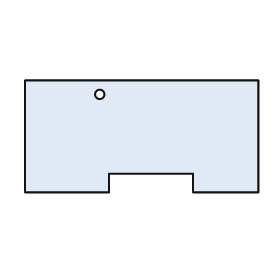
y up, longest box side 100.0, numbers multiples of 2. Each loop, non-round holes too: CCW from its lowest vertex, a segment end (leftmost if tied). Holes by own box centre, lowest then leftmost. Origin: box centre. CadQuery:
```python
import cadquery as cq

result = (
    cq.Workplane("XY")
    .moveTo(-50.0, -24.0)
    .lineTo(-14.0, -24.0)
    .lineTo(-14.0, -16.0)
    .lineTo(22.0, -16.0)
    .lineTo(22.0, -24.0)
    .lineTo(50.0, -24.0)
    .lineTo(50.0, 24.0)
    .lineTo(-50.0, 24.0)
    .close()
    .moveTo(-18.0, 18.0)
    .circle(2.0)
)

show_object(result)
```